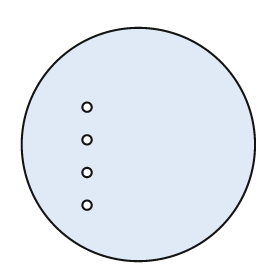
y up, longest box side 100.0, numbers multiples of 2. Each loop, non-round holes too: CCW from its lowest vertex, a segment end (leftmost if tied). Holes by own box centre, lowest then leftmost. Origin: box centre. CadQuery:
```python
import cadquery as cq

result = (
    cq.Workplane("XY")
    .moveTo(0.0, 0.0)
    .circle(50.0)
    .moveTo(-22.0, -26.0)
    .circle(2.0)
    .moveTo(-22.0, -12.0)
    .circle(2.0)
    .moveTo(-22.0, 2.0)
    .circle(2.0)
    .moveTo(-22.0, 16.0)
    .circle(2.0)
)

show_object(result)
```